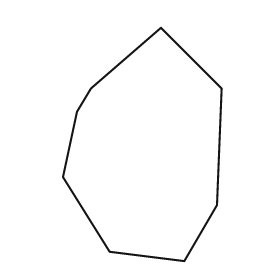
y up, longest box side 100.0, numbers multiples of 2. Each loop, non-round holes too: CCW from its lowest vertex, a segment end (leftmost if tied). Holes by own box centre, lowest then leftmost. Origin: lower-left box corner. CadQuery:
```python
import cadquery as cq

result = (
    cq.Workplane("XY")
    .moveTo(52.0, 0.0)
    .lineTo(66.0, 24.0)
    .lineTo(68.0, 74.0)
    .lineTo(42.0, 100.0)
    .lineTo(12.0, 74.0)
    .lineTo(6.0, 64.0)
    .lineTo(0.0, 36.0)
    .lineTo(20.0, 4.0)
    .close()
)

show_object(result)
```